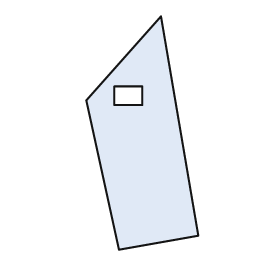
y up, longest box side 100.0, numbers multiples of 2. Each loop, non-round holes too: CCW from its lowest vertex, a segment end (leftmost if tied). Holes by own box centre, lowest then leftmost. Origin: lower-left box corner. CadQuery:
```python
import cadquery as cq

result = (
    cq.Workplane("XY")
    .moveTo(14.0, 0.0)
    .lineTo(48.0, 6.0)
    .lineTo(32.0, 100.0)
    .lineTo(0.0, 64.0)
    .close()
    .moveTo(12.0, 62.0)
    .lineTo(24.0, 62.0)
    .lineTo(24.0, 70.0)
    .lineTo(12.0, 70.0)
    .close()
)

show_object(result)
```